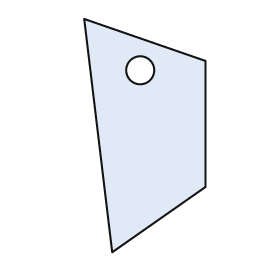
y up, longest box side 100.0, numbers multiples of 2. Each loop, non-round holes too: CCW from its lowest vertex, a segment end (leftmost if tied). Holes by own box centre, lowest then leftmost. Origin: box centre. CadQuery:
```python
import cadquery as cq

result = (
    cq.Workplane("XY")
    .moveTo(-14.0, -50.0)
    .lineTo(26.0, -22.0)
    .lineTo(26.0, 32.0)
    .lineTo(-26.0, 50.0)
    .close()
    .moveTo(-2.0, 28.0)
    .circle(6.0)
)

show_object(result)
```